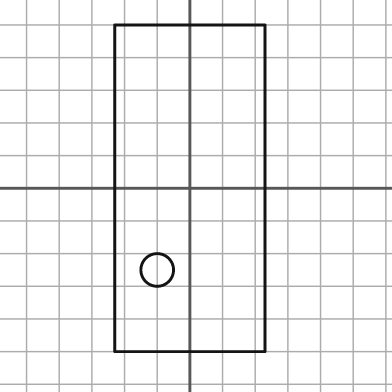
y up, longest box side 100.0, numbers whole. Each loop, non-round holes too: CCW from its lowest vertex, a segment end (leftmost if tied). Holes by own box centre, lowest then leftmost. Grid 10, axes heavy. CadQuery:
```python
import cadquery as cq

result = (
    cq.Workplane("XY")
    .moveTo(-23.0, -50.0)
    .lineTo(23.0, -50.0)
    .lineTo(23.0, 50.0)
    .lineTo(-23.0, 50.0)
    .close()
    .moveTo(-10.0, -25.0)
    .circle(5.0)
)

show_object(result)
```